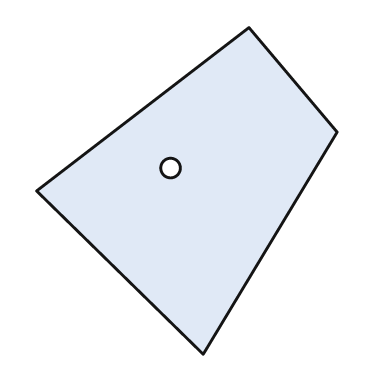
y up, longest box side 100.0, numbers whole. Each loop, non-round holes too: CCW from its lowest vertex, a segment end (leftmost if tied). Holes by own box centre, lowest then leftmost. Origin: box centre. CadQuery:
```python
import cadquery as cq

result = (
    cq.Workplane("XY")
    .moveTo(5.0, -50.0)
    .lineTo(46.0, 18.0)
    .lineTo(19.0, 50.0)
    .lineTo(-46.0, 0.0)
    .close()
    .moveTo(-5.0, 7.0)
    .circle(3.0)
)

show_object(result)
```